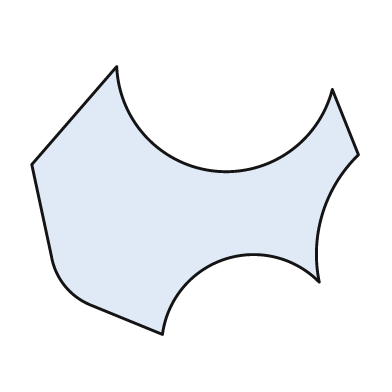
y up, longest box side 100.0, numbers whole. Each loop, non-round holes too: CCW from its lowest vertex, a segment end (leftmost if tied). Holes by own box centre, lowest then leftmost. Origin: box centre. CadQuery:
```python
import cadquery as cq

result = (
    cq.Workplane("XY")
    .moveTo(-10.0, -41.0)
    .threePointArc((9.0, -18.0), (38.0, -25.0))
    .threePointArc((39.0, -4.0), (50.0, 14.0))
    .lineTo(42.0, 34.0)
    .threePointArc((6.0, 9.0), (-24.0, 41.0))
    .lineTo(-50.0, 11.0)
    .lineTo(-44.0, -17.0)
    .threePointArc((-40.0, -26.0), (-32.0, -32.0))
    .close()
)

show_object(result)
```